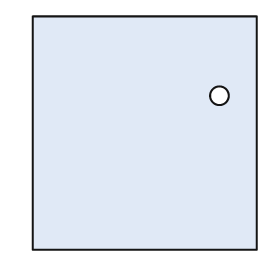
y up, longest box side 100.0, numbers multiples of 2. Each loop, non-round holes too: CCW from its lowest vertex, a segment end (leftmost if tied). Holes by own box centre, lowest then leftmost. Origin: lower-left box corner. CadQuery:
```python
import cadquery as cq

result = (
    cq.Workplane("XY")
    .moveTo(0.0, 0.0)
    .lineTo(96.0, 0.0)
    .lineTo(96.0, 100.0)
    .lineTo(0.0, 100.0)
    .close()
    .moveTo(80.0, 66.0)
    .circle(4.0)
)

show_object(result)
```